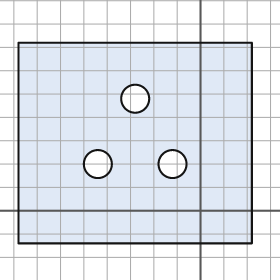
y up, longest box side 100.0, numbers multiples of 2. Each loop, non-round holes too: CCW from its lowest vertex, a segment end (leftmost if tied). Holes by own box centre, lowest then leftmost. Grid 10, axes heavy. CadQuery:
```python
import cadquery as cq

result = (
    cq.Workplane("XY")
    .moveTo(-78.0, -14.0)
    .lineTo(22.0, -14.0)
    .lineTo(22.0, 72.0)
    .lineTo(-78.0, 72.0)
    .close()
    .moveTo(-44.0, 20.0)
    .circle(6.0)
    .moveTo(-12.0, 20.0)
    .circle(6.0)
    .moveTo(-28.0, 48.0)
    .circle(6.0)
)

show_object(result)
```